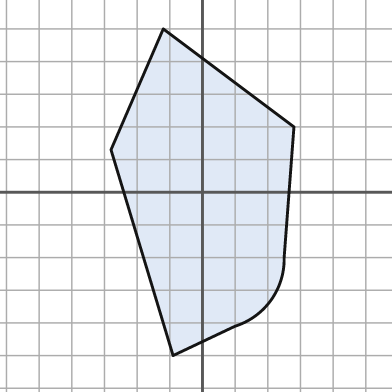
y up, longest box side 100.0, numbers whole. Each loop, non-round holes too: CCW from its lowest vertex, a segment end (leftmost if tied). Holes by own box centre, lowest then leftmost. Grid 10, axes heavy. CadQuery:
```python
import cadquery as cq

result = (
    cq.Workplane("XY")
    .moveTo(-9.0, -50.0)
    .lineTo(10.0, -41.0)
    .threePointArc((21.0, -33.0), (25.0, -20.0))
    .lineTo(28.0, 20.0)
    .lineTo(-12.0, 50.0)
    .lineTo(-28.0, 13.0)
    .close()
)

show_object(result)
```